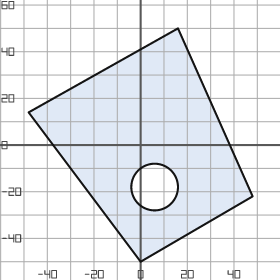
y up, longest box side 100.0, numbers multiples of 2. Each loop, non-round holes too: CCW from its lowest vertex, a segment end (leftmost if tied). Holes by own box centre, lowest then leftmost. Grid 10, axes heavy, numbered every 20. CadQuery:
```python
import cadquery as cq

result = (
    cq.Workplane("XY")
    .moveTo(0.0, -50.0)
    .lineTo(48.0, -22.0)
    .lineTo(16.0, 50.0)
    .lineTo(-48.0, 14.0)
    .close()
    .moveTo(6.0, -18.0)
    .circle(10.0)
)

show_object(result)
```